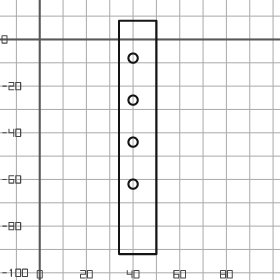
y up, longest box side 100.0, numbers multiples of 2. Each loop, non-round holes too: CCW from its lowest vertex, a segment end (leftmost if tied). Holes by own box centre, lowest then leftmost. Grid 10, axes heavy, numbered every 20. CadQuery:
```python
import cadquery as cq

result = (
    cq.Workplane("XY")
    .moveTo(34.0, -92.0)
    .lineTo(50.0, -92.0)
    .lineTo(50.0, 8.0)
    .lineTo(34.0, 8.0)
    .close()
    .moveTo(40.0, -62.0)
    .circle(2.0)
    .moveTo(40.0, -44.0)
    .circle(2.0)
    .moveTo(40.0, -26.0)
    .circle(2.0)
    .moveTo(40.0, -8.0)
    .circle(2.0)
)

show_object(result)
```